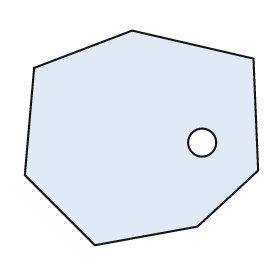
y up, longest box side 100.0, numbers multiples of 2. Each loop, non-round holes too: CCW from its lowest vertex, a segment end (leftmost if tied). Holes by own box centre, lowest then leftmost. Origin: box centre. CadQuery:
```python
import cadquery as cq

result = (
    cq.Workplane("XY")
    .moveTo(-20.0, -46.0)
    .lineTo(24.0, -38.0)
    .lineTo(50.0, -14.0)
    .lineTo(48.0, 34.0)
    .lineTo(-4.0, 46.0)
    .lineTo(-46.0, 30.0)
    .lineTo(-50.0, -16.0)
    .close()
    .moveTo(26.0, -2.0)
    .circle(6.0)
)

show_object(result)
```